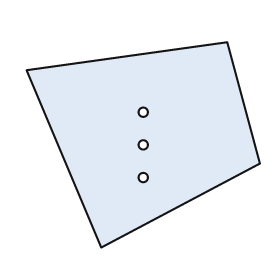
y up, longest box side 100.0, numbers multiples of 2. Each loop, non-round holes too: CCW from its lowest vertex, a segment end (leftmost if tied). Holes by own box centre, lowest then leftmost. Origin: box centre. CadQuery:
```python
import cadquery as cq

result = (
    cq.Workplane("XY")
    .moveTo(-18.0, -44.0)
    .lineTo(50.0, -8.0)
    .lineTo(36.0, 44.0)
    .lineTo(-50.0, 32.0)
    .close()
    .moveTo(0.0, -14.0)
    .circle(2.0)
    .moveTo(0.0, 0.0)
    .circle(2.0)
    .moveTo(0.0, 14.0)
    .circle(2.0)
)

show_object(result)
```